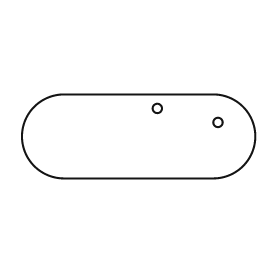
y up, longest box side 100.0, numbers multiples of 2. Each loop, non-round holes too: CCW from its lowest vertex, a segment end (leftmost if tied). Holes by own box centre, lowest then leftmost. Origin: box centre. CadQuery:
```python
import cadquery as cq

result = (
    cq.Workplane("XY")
    .moveTo(-32.0, -18.0)
    .lineTo(32.0, -18.0)
    .threePointArc((50.0, 0.0), (32.0, 18.0))
    .lineTo(-32.0, 18.0)
    .threePointArc((-50.0, 0.0), (-32.0, -18.0))
    .close()
    .moveTo(34.0, 6.0)
    .circle(2.0)
    .moveTo(8.0, 12.0)
    .circle(2.0)
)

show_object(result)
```